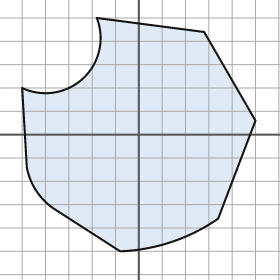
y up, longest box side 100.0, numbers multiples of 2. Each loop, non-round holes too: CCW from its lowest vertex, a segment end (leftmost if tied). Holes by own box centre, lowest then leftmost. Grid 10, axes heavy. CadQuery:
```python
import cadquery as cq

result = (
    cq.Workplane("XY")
    .moveTo(-8.0, -50.0)
    .threePointArc((14.0, -46.0), (34.0, -36.0))
    .lineTo(50.0, 6.0)
    .lineTo(28.0, 44.0)
    .lineTo(-18.0, 50.0)
    .threePointArc((-24.0, 24.0), (-50.0, 20.0))
    .lineTo(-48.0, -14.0)
    .threePointArc((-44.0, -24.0), (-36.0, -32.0))
    .close()
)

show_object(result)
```